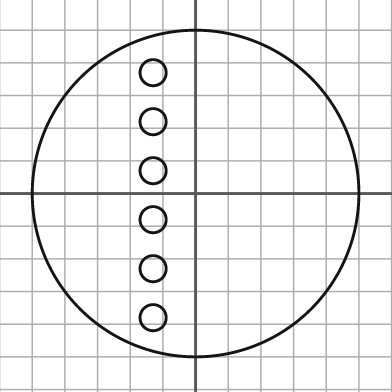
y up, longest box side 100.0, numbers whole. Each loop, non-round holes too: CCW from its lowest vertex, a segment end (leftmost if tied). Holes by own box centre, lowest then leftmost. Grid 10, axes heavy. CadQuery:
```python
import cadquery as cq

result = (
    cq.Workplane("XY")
    .moveTo(0.0, 0.0)
    .circle(50.0)
    .moveTo(-13.0, -38.0)
    .circle(4.0)
    .moveTo(-13.0, -23.0)
    .circle(4.0)
    .moveTo(-13.0, -8.0)
    .circle(4.0)
    .moveTo(-13.0, 7.0)
    .circle(4.0)
    .moveTo(-13.0, 22.0)
    .circle(4.0)
    .moveTo(-13.0, 37.0)
    .circle(4.0)
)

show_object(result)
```